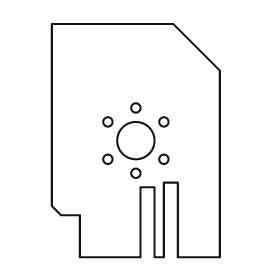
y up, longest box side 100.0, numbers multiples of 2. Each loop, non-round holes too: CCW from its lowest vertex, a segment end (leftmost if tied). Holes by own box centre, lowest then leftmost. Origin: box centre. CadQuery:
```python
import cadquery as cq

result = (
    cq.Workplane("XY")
    .moveTo(-24.0, -50.0)
    .lineTo(2.0, -50.0)
    .lineTo(2.0, -20.0)
    .lineTo(8.0, -20.0)
    .lineTo(8.0, -50.0)
    .lineTo(12.0, -50.0)
    .lineTo(12.0, -18.0)
    .lineTo(18.0, -18.0)
    .lineTo(18.0, -50.0)
    .lineTo(36.0, -50.0)
    .lineTo(36.0, 30.0)
    .lineTo(16.0, 50.0)
    .lineTo(-36.0, 50.0)
    .lineTo(-36.0, -28.0)
    .lineTo(-32.0, -32.0)
    .lineTo(-24.0, -32.0)
    .close()
    .moveTo(0.0, -14.0)
    .circle(2.0)
    .moveTo(-12.0, -8.0)
    .circle(2.0)
    .moveTo(12.0, -8.0)
    .circle(2.0)
    .moveTo(0.0, 0.0)
    .circle(8.0)
    .moveTo(-12.0, 8.0)
    .circle(2.0)
    .moveTo(12.0, 8.0)
    .circle(2.0)
    .moveTo(0.0, 14.0)
    .circle(2.0)
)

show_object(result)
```